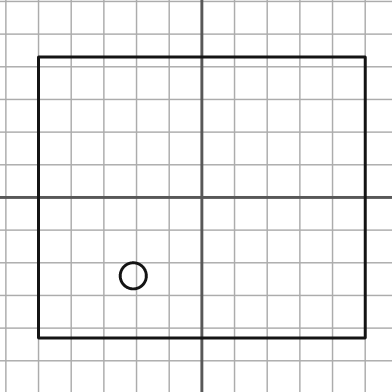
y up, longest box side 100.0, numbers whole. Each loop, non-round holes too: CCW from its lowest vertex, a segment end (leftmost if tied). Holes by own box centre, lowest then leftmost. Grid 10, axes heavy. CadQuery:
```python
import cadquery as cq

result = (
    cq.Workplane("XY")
    .moveTo(-50.0, -43.0)
    .lineTo(50.0, -43.0)
    .lineTo(50.0, 43.0)
    .lineTo(-50.0, 43.0)
    .close()
    .moveTo(-21.0, -24.0)
    .circle(4.0)
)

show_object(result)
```